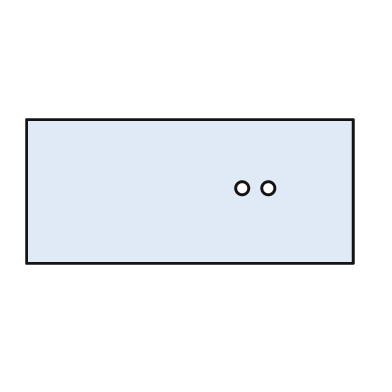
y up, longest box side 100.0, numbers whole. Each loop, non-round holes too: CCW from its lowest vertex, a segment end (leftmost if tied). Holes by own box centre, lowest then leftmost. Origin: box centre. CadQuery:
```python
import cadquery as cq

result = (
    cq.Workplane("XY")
    .moveTo(-50.0, -22.0)
    .lineTo(50.0, -22.0)
    .lineTo(50.0, 22.0)
    .lineTo(-50.0, 22.0)
    .close()
    .moveTo(16.0, 1.0)
    .circle(2.0)
    .moveTo(24.0, 1.0)
    .circle(2.0)
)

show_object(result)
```